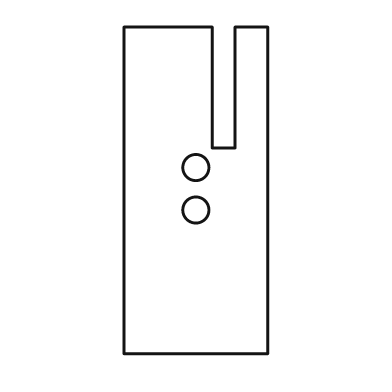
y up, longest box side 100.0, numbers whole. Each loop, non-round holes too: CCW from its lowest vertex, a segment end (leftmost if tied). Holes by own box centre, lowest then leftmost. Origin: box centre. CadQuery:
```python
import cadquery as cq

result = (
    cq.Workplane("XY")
    .moveTo(-22.0, -50.0)
    .lineTo(22.0, -50.0)
    .lineTo(22.0, 50.0)
    .lineTo(12.0, 50.0)
    .lineTo(12.0, 13.0)
    .lineTo(5.0, 13.0)
    .lineTo(5.0, 50.0)
    .lineTo(-22.0, 50.0)
    .close()
    .moveTo(0.0, -6.0)
    .circle(4.0)
    .moveTo(0.0, 7.0)
    .circle(4.0)
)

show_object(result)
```